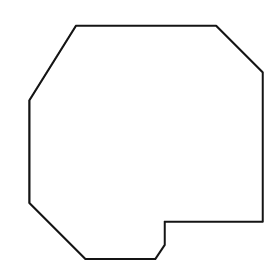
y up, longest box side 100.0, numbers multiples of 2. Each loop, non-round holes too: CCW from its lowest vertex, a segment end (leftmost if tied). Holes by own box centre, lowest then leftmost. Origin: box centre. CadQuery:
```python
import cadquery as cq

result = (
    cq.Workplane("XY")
    .moveTo(-26.0, -50.0)
    .lineTo(4.0, -50.0)
    .lineTo(8.0, -44.0)
    .lineTo(8.0, -34.0)
    .lineTo(50.0, -34.0)
    .lineTo(50.0, 30.0)
    .lineTo(30.0, 50.0)
    .lineTo(-30.0, 50.0)
    .lineTo(-50.0, 18.0)
    .lineTo(-50.0, -26.0)
    .close()
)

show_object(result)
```